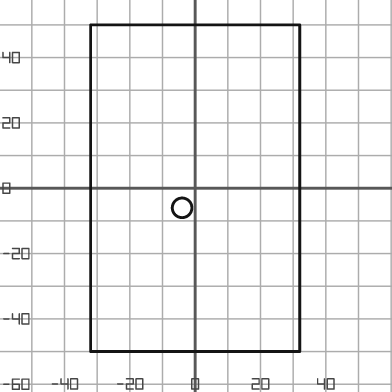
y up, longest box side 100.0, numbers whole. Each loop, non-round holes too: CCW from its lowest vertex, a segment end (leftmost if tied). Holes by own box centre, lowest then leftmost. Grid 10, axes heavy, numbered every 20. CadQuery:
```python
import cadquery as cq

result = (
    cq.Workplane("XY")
    .moveTo(-32.0, -50.0)
    .lineTo(32.0, -50.0)
    .lineTo(32.0, 50.0)
    .lineTo(-32.0, 50.0)
    .close()
    .moveTo(-4.0, -6.0)
    .circle(3.0)
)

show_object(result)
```